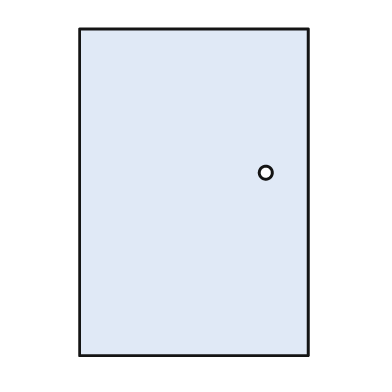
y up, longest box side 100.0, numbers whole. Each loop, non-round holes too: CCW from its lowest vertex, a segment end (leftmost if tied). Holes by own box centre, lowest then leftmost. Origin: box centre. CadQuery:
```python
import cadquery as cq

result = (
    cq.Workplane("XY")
    .moveTo(-35.0, -50.0)
    .lineTo(35.0, -50.0)
    .lineTo(35.0, 50.0)
    .lineTo(-35.0, 50.0)
    .close()
    .moveTo(22.0, 6.0)
    .circle(2.0)
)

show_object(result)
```